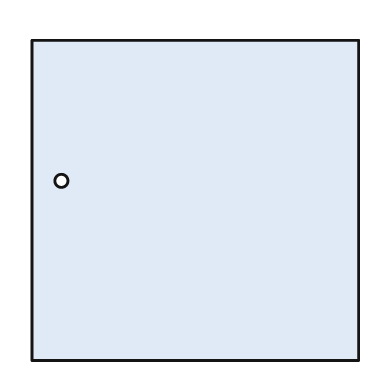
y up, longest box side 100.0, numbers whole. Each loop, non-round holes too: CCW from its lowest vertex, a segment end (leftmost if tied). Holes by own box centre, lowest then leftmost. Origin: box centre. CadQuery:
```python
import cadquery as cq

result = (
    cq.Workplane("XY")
    .moveTo(-50.0, -49.0)
    .lineTo(50.0, -49.0)
    .lineTo(50.0, 49.0)
    .lineTo(-50.0, 49.0)
    .close()
    .moveTo(-41.0, 6.0)
    .circle(2.0)
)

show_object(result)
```